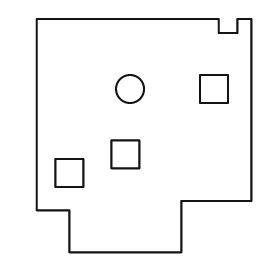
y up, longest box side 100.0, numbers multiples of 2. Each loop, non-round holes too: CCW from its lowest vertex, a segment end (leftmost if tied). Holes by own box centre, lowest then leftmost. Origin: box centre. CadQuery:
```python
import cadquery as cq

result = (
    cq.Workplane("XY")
    .moveTo(-32.0, -50.0)
    .lineTo(16.0, -50.0)
    .lineTo(16.0, -28.0)
    .lineTo(46.0, -28.0)
    .lineTo(46.0, 50.0)
    .lineTo(40.0, 50.0)
    .lineTo(40.0, 44.0)
    .lineTo(32.0, 44.0)
    .lineTo(32.0, 50.0)
    .lineTo(-46.0, 50.0)
    .lineTo(-46.0, -32.0)
    .lineTo(-32.0, -32.0)
    .close()
    .moveTo(-38.0, -22.0)
    .lineTo(-26.0, -22.0)
    .lineTo(-26.0, -10.0)
    .lineTo(-38.0, -10.0)
    .close()
    .moveTo(-14.0, -14.0)
    .lineTo(-2.0, -14.0)
    .lineTo(-2.0, -2.0)
    .lineTo(-14.0, -2.0)
    .close()
    .moveTo(-6.0, 20.0)
    .circle(6.0)
    .moveTo(24.0, 14.0)
    .lineTo(36.0, 14.0)
    .lineTo(36.0, 26.0)
    .lineTo(24.0, 26.0)
    .close()
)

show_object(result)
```